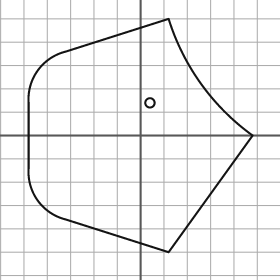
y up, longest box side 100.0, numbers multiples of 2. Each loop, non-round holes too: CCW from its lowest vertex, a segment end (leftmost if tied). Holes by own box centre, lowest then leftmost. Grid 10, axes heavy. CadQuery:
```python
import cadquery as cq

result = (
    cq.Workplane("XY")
    .moveTo(12.0, -50.0)
    .lineTo(48.0, 0.0)
    .threePointArc((26.0, 22.0), (12.0, 50.0))
    .lineTo(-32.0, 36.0)
    .threePointArc((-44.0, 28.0), (-48.0, 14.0))
    .lineTo(-48.0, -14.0)
    .threePointArc((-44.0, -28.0), (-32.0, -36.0))
    .close()
    .moveTo(4.0, 14.0)
    .circle(2.0)
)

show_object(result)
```